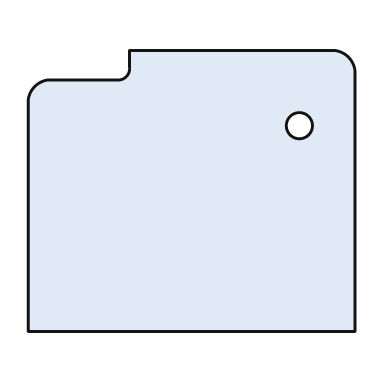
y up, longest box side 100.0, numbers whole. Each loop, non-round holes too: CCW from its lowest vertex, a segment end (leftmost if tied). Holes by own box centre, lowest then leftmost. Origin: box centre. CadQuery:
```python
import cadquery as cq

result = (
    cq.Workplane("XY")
    .moveTo(-50.0, -43.0)
    .lineTo(50.0, -43.0)
    .lineTo(50.0, 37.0)
    .threePointArc((48.0, 41.0), (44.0, 43.0))
    .lineTo(-19.0, 43.0)
    .lineTo(-19.0, 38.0)
    .threePointArc((-20.0, 35.0), (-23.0, 34.0))
    .lineTo(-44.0, 34.0)
    .threePointArc((-48.0, 32.0), (-50.0, 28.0))
    .close()
    .moveTo(33.0, 20.0)
    .circle(4.0)
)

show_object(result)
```